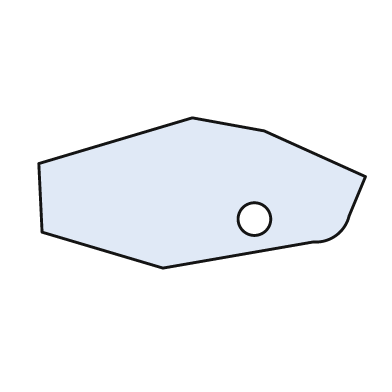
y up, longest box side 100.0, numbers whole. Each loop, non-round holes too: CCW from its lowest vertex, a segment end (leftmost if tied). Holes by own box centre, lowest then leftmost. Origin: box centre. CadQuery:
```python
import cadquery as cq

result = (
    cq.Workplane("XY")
    .moveTo(-12.0, -23.0)
    .lineTo(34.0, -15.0)
    .threePointArc((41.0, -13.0), (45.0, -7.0))
    .lineTo(50.0, 5.0)
    .lineTo(19.0, 19.0)
    .lineTo(-3.0, 23.0)
    .lineTo(-50.0, 9.0)
    .lineTo(-49.0, -12.0)
    .close()
    .moveTo(16.0, -8.0)
    .circle(5.0)
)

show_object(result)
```